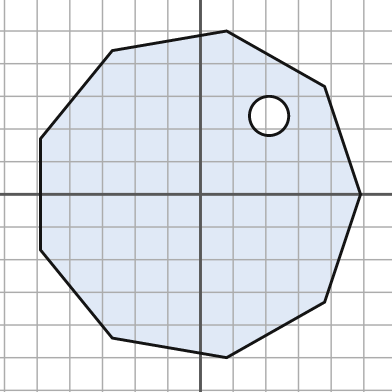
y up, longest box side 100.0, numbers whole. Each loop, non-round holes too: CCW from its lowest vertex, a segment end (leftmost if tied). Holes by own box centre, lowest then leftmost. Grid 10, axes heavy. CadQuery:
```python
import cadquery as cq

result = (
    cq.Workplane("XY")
    .moveTo(8.0, -50.0)
    .lineTo(38.0, -33.0)
    .lineTo(49.0, 0.0)
    .lineTo(38.0, 33.0)
    .lineTo(8.0, 50.0)
    .lineTo(-27.0, 44.0)
    .lineTo(-49.0, 17.0)
    .lineTo(-49.0, -17.0)
    .lineTo(-27.0, -44.0)
    .close()
    .moveTo(21.0, 24.0)
    .circle(6.0)
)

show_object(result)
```